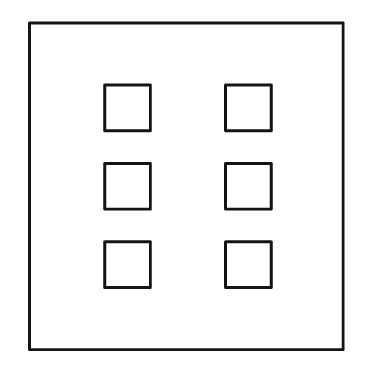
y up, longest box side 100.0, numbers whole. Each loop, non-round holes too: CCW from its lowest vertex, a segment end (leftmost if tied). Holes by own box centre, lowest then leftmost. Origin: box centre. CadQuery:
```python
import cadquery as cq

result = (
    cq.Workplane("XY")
    .moveTo(-48.0, -50.0)
    .lineTo(48.0, -50.0)
    .lineTo(48.0, 50.0)
    .lineTo(-48.0, 50.0)
    .close()
    .moveTo(-25.0, -31.0)
    .lineTo(-11.0, -31.0)
    .lineTo(-11.0, -17.0)
    .lineTo(-25.0, -17.0)
    .close()
    .moveTo(12.0, -31.0)
    .lineTo(26.0, -31.0)
    .lineTo(26.0, -17.0)
    .lineTo(12.0, -17.0)
    .close()
    .moveTo(-25.0, -7.0)
    .lineTo(-11.0, -7.0)
    .lineTo(-11.0, 7.0)
    .lineTo(-25.0, 7.0)
    .close()
    .moveTo(12.0, -7.0)
    .lineTo(26.0, -7.0)
    .lineTo(26.0, 7.0)
    .lineTo(12.0, 7.0)
    .close()
    .moveTo(-25.0, 17.0)
    .lineTo(-11.0, 17.0)
    .lineTo(-11.0, 31.0)
    .lineTo(-25.0, 31.0)
    .close()
    .moveTo(12.0, 17.0)
    .lineTo(26.0, 17.0)
    .lineTo(26.0, 31.0)
    .lineTo(12.0, 31.0)
    .close()
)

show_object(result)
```